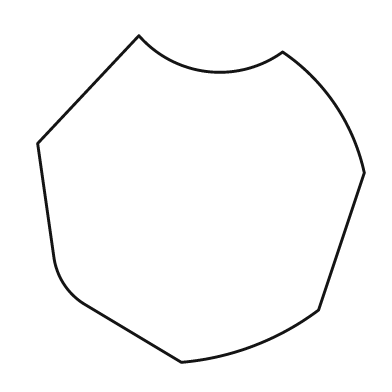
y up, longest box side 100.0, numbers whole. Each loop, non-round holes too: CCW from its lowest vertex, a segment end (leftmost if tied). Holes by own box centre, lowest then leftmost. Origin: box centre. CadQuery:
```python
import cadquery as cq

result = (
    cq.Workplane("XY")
    .moveTo(-6.0, -50.0)
    .threePointArc((16.0, -45.0), (36.0, -34.0))
    .lineTo(50.0, 8.0)
    .threePointArc((41.0, 29.0), (25.0, 45.0))
    .threePointArc((2.0, 39.0), (-19.0, 50.0))
    .lineTo(-50.0, 17.0)
    .lineTo(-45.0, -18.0)
    .threePointArc((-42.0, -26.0), (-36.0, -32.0))
    .close()
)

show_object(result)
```